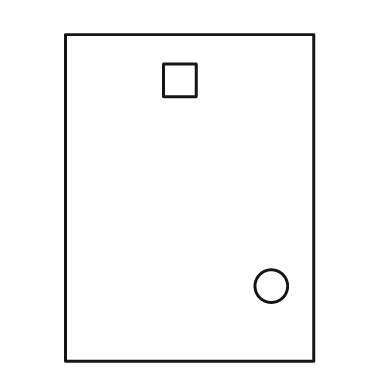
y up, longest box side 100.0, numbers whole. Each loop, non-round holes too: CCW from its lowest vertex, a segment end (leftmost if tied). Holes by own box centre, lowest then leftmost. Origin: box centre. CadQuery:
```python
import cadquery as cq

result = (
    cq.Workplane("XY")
    .moveTo(-38.0, -50.0)
    .lineTo(38.0, -50.0)
    .lineTo(38.0, 50.0)
    .lineTo(-38.0, 50.0)
    .close()
    .moveTo(25.0, -27.0)
    .circle(5.0)
    .moveTo(-8.0, 31.0)
    .lineTo(2.0, 31.0)
    .lineTo(2.0, 41.0)
    .lineTo(-8.0, 41.0)
    .close()
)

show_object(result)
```